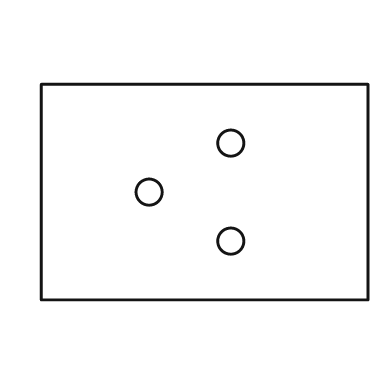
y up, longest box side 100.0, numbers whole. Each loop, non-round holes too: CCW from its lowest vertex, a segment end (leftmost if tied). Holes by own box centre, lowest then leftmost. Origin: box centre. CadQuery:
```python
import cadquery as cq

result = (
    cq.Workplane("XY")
    .moveTo(-50.0, -33.0)
    .lineTo(50.0, -33.0)
    .lineTo(50.0, 33.0)
    .lineTo(-50.0, 33.0)
    .close()
    .moveTo(8.0, -15.0)
    .circle(4.0)
    .moveTo(-17.0, 0.0)
    .circle(4.0)
    .moveTo(8.0, 15.0)
    .circle(4.0)
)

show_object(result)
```